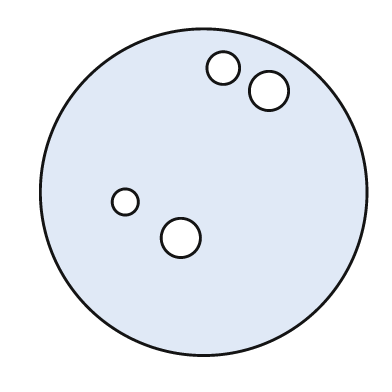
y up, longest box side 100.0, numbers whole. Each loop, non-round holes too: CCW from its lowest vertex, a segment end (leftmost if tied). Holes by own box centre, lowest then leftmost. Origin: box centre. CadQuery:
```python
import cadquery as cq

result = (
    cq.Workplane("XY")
    .moveTo(0.0, 0.0)
    .circle(50.0)
    .moveTo(-7.0, -14.0)
    .circle(6.0)
    .moveTo(-24.0, -3.0)
    .circle(4.0)
    .moveTo(20.0, 31.0)
    .circle(6.0)
    .moveTo(6.0, 38.0)
    .circle(5.0)
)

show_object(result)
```